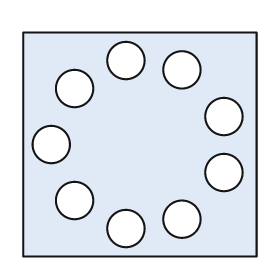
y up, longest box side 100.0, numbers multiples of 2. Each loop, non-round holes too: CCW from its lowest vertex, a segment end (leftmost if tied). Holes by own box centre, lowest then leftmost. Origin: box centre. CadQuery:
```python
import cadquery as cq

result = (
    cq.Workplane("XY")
    .moveTo(-50.0, -48.0)
    .lineTo(50.0, -48.0)
    .lineTo(50.0, 48.0)
    .lineTo(-50.0, 48.0)
    .close()
    .moveTo(-6.0, -36.0)
    .circle(8.0)
    .moveTo(18.0, -32.0)
    .circle(8.0)
    .moveTo(-28.0, -24.0)
    .circle(8.0)
    .moveTo(36.0, -12.0)
    .circle(8.0)
    .moveTo(-38.0, 0.0)
    .circle(8.0)
    .moveTo(36.0, 12.0)
    .circle(8.0)
    .moveTo(-28.0, 24.0)
    .circle(8.0)
    .moveTo(18.0, 32.0)
    .circle(8.0)
    .moveTo(-6.0, 36.0)
    .circle(8.0)
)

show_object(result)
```